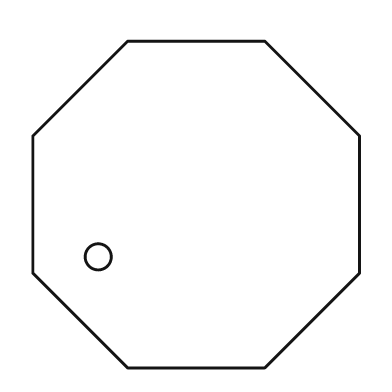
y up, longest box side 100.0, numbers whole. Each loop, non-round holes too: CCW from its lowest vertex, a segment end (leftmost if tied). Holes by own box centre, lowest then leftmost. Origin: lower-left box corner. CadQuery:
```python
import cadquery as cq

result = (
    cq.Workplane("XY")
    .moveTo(29.0, 0.0)
    .lineTo(71.0, 0.0)
    .lineTo(100.0, 29.0)
    .lineTo(100.0, 71.0)
    .lineTo(71.0, 100.0)
    .lineTo(29.0, 100.0)
    .lineTo(0.0, 71.0)
    .lineTo(0.0, 29.0)
    .close()
    .moveTo(20.0, 34.0)
    .circle(4.0)
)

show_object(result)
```